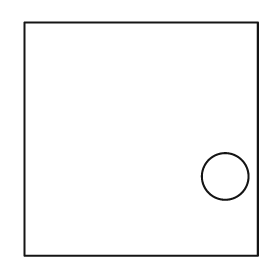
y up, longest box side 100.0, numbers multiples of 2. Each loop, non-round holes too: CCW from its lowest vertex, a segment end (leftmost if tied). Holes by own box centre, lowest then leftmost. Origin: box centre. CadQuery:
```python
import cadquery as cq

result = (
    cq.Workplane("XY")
    .moveTo(-50.0, -50.0)
    .lineTo(50.0, -50.0)
    .lineTo(50.0, 50.0)
    .lineTo(-50.0, 50.0)
    .close()
    .moveTo(36.0, -16.0)
    .circle(10.0)
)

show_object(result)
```